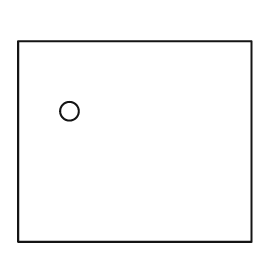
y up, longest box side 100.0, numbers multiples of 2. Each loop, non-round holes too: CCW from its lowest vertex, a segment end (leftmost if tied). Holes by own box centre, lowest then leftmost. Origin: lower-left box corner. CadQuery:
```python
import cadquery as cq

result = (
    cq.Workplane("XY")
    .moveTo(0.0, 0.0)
    .lineTo(100.0, 0.0)
    .lineTo(100.0, 86.0)
    .lineTo(0.0, 86.0)
    .close()
    .moveTo(22.0, 56.0)
    .circle(4.0)
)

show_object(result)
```